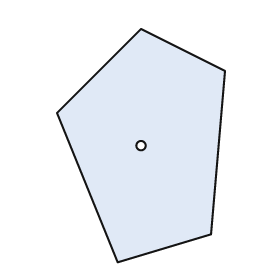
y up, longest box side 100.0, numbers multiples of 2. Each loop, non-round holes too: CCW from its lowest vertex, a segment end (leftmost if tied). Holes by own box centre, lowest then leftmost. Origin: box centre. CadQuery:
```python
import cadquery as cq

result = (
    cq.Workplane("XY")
    .moveTo(-10.0, -50.0)
    .lineTo(30.0, -38.0)
    .lineTo(36.0, 32.0)
    .lineTo(0.0, 50.0)
    .lineTo(-36.0, 14.0)
    .close()
    .moveTo(0.0, 0.0)
    .circle(2.0)
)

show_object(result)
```